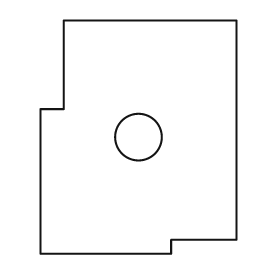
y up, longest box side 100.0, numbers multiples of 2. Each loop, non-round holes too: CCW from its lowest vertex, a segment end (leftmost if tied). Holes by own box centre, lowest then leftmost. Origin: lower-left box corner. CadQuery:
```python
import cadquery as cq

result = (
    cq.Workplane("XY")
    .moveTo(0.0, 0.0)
    .lineTo(56.0, 0.0)
    .lineTo(56.0, 6.0)
    .lineTo(84.0, 6.0)
    .lineTo(84.0, 100.0)
    .lineTo(10.0, 100.0)
    .lineTo(10.0, 62.0)
    .lineTo(0.0, 62.0)
    .close()
    .moveTo(42.0, 50.0)
    .circle(10.0)
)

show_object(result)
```